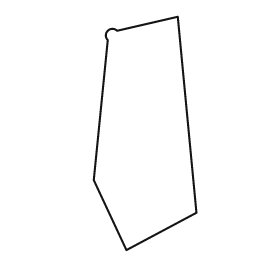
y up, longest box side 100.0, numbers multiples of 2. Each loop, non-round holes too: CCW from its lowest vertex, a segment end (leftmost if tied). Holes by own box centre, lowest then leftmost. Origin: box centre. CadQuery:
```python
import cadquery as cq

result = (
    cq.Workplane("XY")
    .moveTo(-8.0, -50.0)
    .lineTo(22.0, -34.0)
    .lineTo(14.0, 50.0)
    .lineTo(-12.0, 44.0)
    .threePointArc((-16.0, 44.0), (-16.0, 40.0))
    .lineTo(-22.0, -20.0)
    .close()
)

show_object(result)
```